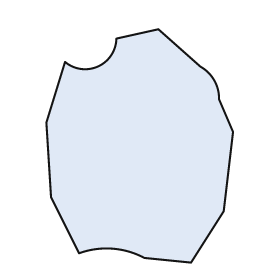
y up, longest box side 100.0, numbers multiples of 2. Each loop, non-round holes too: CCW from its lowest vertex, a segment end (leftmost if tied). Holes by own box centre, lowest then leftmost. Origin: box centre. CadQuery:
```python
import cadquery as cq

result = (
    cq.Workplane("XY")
    .moveTo(22.0, -50.0)
    .lineTo(36.0, -28.0)
    .lineTo(40.0, 6.0)
    .lineTo(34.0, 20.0)
    .threePointArc((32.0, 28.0), (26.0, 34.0))
    .lineTo(8.0, 50.0)
    .lineTo(-10.0, 46.0)
    .threePointArc((-18.0, 34.0), (-32.0, 36.0))
    .lineTo(-40.0, 10.0)
    .lineTo(-38.0, -22.0)
    .lineTo(-26.0, -46.0)
    .threePointArc((-12.0, -44.0), (2.0, -48.0))
    .close()
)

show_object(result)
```